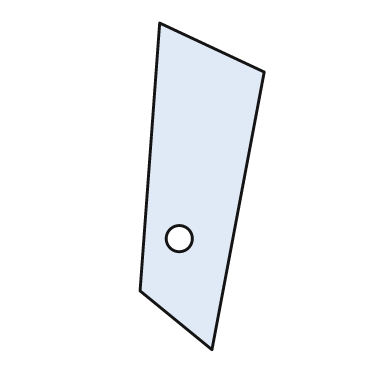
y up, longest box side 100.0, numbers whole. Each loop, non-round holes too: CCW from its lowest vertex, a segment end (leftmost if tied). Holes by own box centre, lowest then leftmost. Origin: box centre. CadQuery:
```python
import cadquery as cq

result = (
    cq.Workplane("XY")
    .moveTo(3.0, -50.0)
    .lineTo(19.0, 35.0)
    .lineTo(-13.0, 50.0)
    .lineTo(-19.0, -32.0)
    .close()
    .moveTo(-7.0, -16.0)
    .circle(4.0)
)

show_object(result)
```